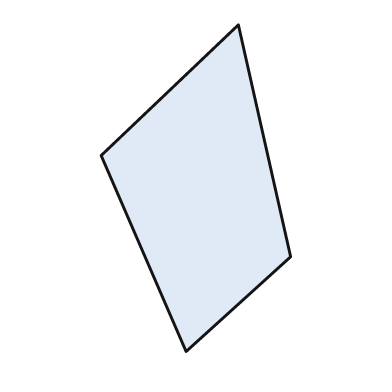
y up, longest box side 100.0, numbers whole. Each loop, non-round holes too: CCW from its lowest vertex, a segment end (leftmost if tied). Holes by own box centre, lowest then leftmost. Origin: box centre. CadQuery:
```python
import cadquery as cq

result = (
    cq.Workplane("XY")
    .moveTo(-3.0, -50.0)
    .lineTo(29.0, -21.0)
    .lineTo(13.0, 50.0)
    .lineTo(-29.0, 10.0)
    .close()
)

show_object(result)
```